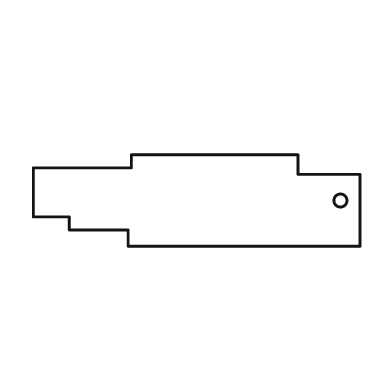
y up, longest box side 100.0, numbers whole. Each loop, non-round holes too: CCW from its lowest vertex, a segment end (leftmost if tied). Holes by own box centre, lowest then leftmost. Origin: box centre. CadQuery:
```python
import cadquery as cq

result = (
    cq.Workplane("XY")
    .moveTo(-21.0, -14.0)
    .lineTo(50.0, -14.0)
    .lineTo(50.0, 8.0)
    .lineTo(31.0, 8.0)
    .lineTo(31.0, 14.0)
    .lineTo(-20.0, 14.0)
    .lineTo(-20.0, 10.0)
    .lineTo(-50.0, 10.0)
    .lineTo(-50.0, -5.0)
    .lineTo(-39.0, -5.0)
    .lineTo(-39.0, -9.0)
    .lineTo(-21.0, -9.0)
    .close()
    .moveTo(44.0, 0.0)
    .circle(2.0)
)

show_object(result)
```